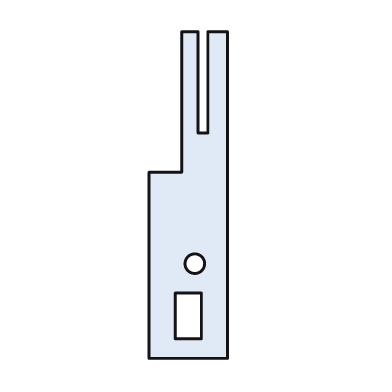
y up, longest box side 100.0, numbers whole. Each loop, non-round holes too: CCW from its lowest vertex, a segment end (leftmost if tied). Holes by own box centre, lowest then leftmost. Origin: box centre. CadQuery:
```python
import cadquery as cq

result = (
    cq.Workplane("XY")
    .moveTo(-12.0, -50.0)
    .lineTo(12.0, -50.0)
    .lineTo(12.0, 50.0)
    .lineTo(6.0, 50.0)
    .lineTo(6.0, 19.0)
    .lineTo(3.0, 19.0)
    .lineTo(3.0, 50.0)
    .lineTo(-2.0, 50.0)
    .lineTo(-2.0, 7.0)
    .lineTo(-12.0, 7.0)
    .close()
    .moveTo(-4.0, -44.0)
    .lineTo(4.0, -44.0)
    .lineTo(4.0, -30.0)
    .lineTo(-4.0, -30.0)
    .close()
    .moveTo(2.0, -21.0)
    .circle(3.0)
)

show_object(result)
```